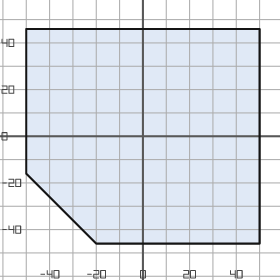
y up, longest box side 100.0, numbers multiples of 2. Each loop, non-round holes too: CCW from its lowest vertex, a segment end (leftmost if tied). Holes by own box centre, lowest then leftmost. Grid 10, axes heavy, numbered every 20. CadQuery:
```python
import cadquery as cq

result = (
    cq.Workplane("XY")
    .moveTo(-20.0, -46.0)
    .lineTo(50.0, -46.0)
    .lineTo(50.0, 46.0)
    .lineTo(-50.0, 46.0)
    .lineTo(-50.0, -16.0)
    .close()
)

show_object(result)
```